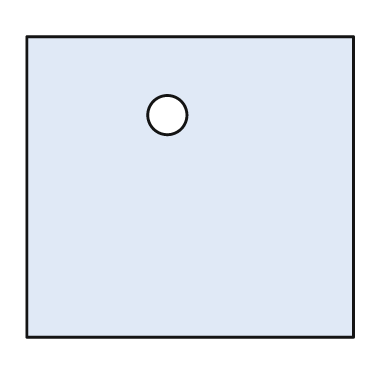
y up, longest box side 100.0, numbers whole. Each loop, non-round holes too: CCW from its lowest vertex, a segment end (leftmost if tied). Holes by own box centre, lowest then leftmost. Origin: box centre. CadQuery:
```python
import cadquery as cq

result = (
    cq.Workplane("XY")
    .moveTo(-50.0, -46.0)
    .lineTo(50.0, -46.0)
    .lineTo(50.0, 46.0)
    .lineTo(-50.0, 46.0)
    .close()
    .moveTo(-7.0, 22.0)
    .circle(6.0)
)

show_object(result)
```